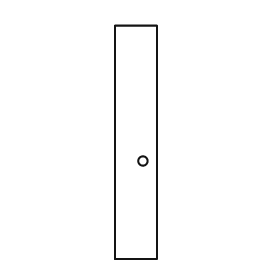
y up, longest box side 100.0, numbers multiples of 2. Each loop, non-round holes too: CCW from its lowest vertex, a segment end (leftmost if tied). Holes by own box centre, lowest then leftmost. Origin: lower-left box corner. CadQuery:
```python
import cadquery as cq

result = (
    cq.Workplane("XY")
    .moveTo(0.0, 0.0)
    .lineTo(18.0, 0.0)
    .lineTo(18.0, 100.0)
    .lineTo(0.0, 100.0)
    .close()
    .moveTo(12.0, 42.0)
    .circle(2.0)
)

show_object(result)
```